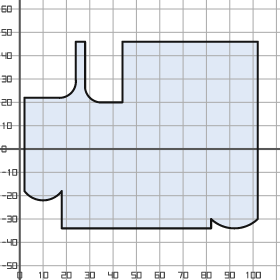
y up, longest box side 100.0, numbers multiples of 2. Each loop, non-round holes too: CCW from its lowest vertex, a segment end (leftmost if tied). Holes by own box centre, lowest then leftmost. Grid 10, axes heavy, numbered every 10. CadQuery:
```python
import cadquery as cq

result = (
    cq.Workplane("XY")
    .moveTo(18.0, -34.0)
    .lineTo(82.0, -34.0)
    .lineTo(82.0, -30.0)
    .threePointArc((92.0, -34.0), (102.0, -30.0))
    .lineTo(102.0, 46.0)
    .lineTo(44.0, 46.0)
    .lineTo(44.0, 20.0)
    .lineTo(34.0, 20.0)
    .threePointArc((30.0, 22.0), (28.0, 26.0))
    .lineTo(28.0, 46.0)
    .lineTo(24.0, 46.0)
    .lineTo(24.0, 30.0)
    .threePointArc((22.0, 24.0), (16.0, 22.0))
    .lineTo(2.0, 22.0)
    .lineTo(2.0, -18.0)
    .threePointArc((10.0, -22.0), (18.0, -18.0))
    .close()
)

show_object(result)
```